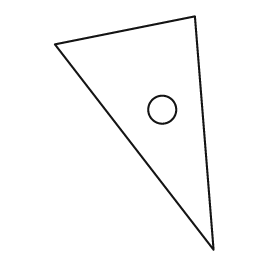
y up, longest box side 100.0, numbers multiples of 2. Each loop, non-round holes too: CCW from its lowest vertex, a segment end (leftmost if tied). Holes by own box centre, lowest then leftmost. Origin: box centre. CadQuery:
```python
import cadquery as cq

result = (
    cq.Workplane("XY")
    .moveTo(34.0, -50.0)
    .lineTo(26.0, 50.0)
    .lineTo(-34.0, 38.0)
    .close()
    .moveTo(12.0, 10.0)
    .circle(6.0)
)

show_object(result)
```